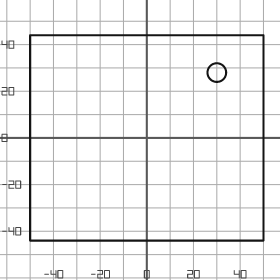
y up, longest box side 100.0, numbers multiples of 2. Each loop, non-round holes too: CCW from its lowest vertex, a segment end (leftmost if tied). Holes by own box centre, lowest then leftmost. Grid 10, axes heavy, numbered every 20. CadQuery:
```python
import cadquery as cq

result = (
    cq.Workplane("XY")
    .moveTo(-50.0, -44.0)
    .lineTo(50.0, -44.0)
    .lineTo(50.0, 44.0)
    .lineTo(-50.0, 44.0)
    .close()
    .moveTo(30.0, 28.0)
    .circle(4.0)
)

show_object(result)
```